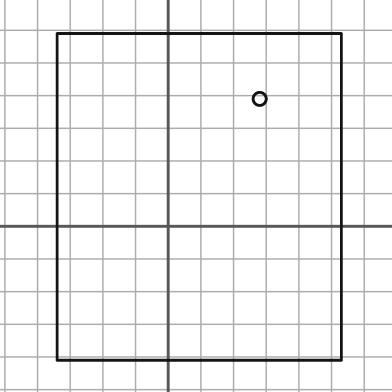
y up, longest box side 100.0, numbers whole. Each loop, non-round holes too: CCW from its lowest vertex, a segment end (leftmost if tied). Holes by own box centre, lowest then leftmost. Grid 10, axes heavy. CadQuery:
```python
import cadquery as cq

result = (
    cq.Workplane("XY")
    .moveTo(-34.0, -41.0)
    .lineTo(53.0, -41.0)
    .lineTo(53.0, 59.0)
    .lineTo(-34.0, 59.0)
    .close()
    .moveTo(28.0, 39.0)
    .circle(2.0)
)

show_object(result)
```